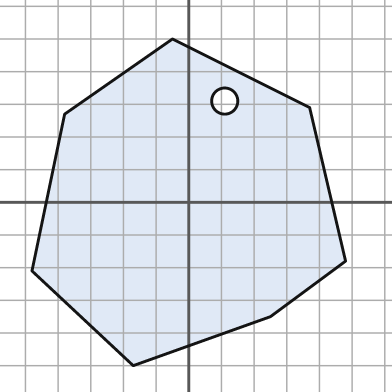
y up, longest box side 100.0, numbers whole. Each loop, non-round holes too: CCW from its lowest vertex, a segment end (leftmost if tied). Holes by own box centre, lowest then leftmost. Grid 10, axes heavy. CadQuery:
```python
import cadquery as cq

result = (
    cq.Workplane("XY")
    .moveTo(-17.0, -50.0)
    .lineTo(25.0, -35.0)
    .lineTo(48.0, -18.0)
    .lineTo(37.0, 29.0)
    .lineTo(-5.0, 50.0)
    .lineTo(-38.0, 27.0)
    .lineTo(-48.0, -21.0)
    .close()
    .moveTo(11.0, 31.0)
    .circle(4.0)
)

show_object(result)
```